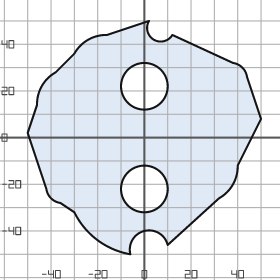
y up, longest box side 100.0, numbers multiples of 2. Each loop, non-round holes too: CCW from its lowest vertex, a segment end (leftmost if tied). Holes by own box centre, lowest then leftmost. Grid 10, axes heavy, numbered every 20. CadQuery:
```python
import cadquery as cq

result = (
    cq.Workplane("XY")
    .moveTo(-6.0, -50.0)
    .threePointArc((0.0, -40.0), (10.0, -46.0))
    .lineTo(32.0, -26.0)
    .threePointArc((38.0, -20.0), (40.0, -12.0))
    .lineTo(50.0, 8.0)
    .lineTo(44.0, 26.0)
    .threePointArc((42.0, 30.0), (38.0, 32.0))
    .lineTo(12.0, 44.0)
    .threePointArc((4.0, 42.0), (2.0, 50.0))
    .lineTo(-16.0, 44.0)
    .threePointArc((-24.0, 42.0), (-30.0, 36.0))
    .lineTo(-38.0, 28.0)
    .threePointArc((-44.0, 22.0), (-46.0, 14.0))
    .lineTo(-50.0, 2.0)
    .lineTo(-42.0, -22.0)
    .threePointArc((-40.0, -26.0), (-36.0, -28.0))
    .lineTo(-30.0, -32.0)
    .threePointArc((-20.0, -44.0), (-6.0, -50.0))
    .close()
    .moveTo(0.0, -22.0)
    .circle(10.0)
    .moveTo(0.0, 22.0)
    .circle(10.0)
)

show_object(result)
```